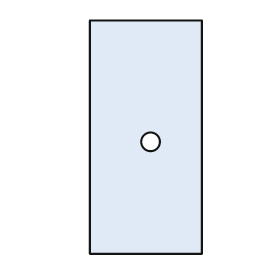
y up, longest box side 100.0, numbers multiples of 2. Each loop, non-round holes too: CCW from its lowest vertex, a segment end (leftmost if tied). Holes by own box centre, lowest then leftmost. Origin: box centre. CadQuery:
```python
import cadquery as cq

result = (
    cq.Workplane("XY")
    .moveTo(-24.0, -50.0)
    .lineTo(24.0, -50.0)
    .lineTo(24.0, 50.0)
    .lineTo(-24.0, 50.0)
    .close()
    .moveTo(2.0, -2.0)
    .circle(4.0)
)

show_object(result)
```